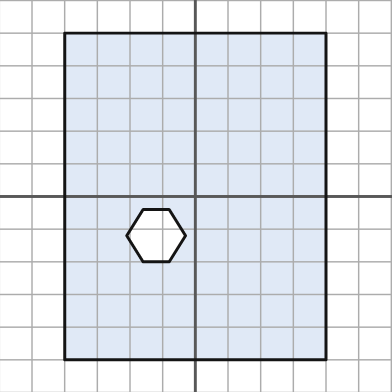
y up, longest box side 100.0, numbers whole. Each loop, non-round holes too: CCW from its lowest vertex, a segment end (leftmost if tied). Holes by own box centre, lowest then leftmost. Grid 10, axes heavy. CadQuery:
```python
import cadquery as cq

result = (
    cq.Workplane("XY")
    .moveTo(-40.0, -50.0)
    .lineTo(40.0, -50.0)
    .lineTo(40.0, 50.0)
    .lineTo(-40.0, 50.0)
    .close()
    .moveTo(-16.0, -20.0)
    .lineTo(-8.0, -20.0)
    .lineTo(-3.0, -12.0)
    .lineTo(-8.0, -4.0)
    .lineTo(-16.0, -4.0)
    .lineTo(-21.0, -12.0)
    .close()
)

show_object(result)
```